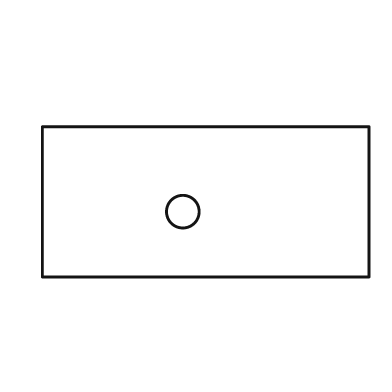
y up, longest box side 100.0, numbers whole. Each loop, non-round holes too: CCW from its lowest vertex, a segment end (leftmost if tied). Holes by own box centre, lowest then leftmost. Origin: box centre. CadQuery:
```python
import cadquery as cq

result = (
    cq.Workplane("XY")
    .moveTo(-50.0, -23.0)
    .lineTo(50.0, -23.0)
    .lineTo(50.0, 23.0)
    .lineTo(-50.0, 23.0)
    .close()
    .moveTo(-7.0, -3.0)
    .circle(5.0)
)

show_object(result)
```